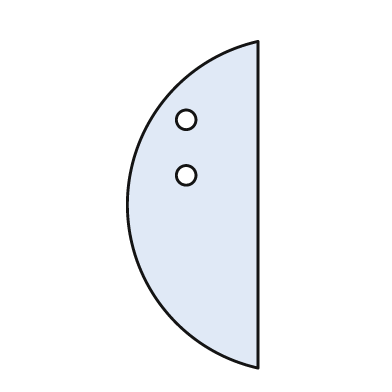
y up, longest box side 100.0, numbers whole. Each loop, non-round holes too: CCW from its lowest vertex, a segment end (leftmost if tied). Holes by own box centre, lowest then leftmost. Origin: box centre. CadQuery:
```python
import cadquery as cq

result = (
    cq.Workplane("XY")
    .moveTo(20.0, -50.0)
    .lineTo(20.0, 50.0)
    .threePointArc((-20.0, 0.0), (20.0, -50.0))
    .close()
    .moveTo(-2.0, 9.0)
    .circle(3.0)
    .moveTo(-2.0, 26.0)
    .circle(3.0)
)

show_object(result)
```